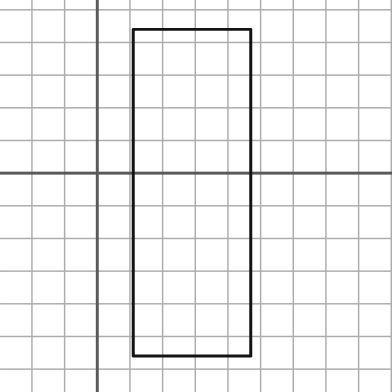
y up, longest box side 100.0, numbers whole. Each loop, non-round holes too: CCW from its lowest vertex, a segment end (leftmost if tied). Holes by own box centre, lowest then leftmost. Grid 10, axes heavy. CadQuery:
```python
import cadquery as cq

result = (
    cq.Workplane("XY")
    .moveTo(11.0, -56.0)
    .lineTo(47.0, -56.0)
    .lineTo(47.0, 44.0)
    .lineTo(11.0, 44.0)
    .close()
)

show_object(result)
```